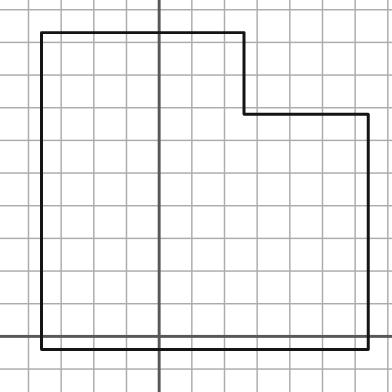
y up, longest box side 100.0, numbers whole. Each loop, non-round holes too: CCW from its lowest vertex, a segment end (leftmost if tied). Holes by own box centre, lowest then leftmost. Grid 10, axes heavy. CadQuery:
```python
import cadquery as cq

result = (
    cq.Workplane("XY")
    .moveTo(-36.0, -4.0)
    .lineTo(64.0, -4.0)
    .lineTo(64.0, 68.0)
    .lineTo(26.0, 68.0)
    .lineTo(26.0, 93.0)
    .lineTo(-36.0, 93.0)
    .close()
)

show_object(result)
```